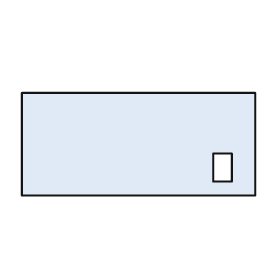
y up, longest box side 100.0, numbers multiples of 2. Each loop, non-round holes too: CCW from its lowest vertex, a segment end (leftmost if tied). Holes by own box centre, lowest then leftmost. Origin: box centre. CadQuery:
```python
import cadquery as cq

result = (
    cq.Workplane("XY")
    .moveTo(-50.0, -22.0)
    .lineTo(50.0, -22.0)
    .lineTo(50.0, 22.0)
    .lineTo(-50.0, 22.0)
    .close()
    .moveTo(32.0, -16.0)
    .lineTo(40.0, -16.0)
    .lineTo(40.0, -4.0)
    .lineTo(32.0, -4.0)
    .close()
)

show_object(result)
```